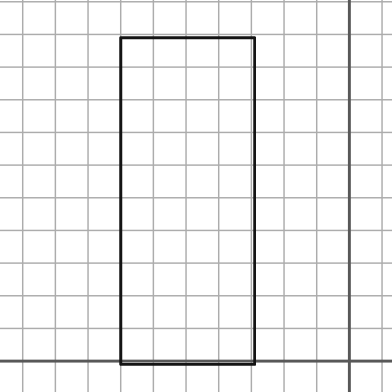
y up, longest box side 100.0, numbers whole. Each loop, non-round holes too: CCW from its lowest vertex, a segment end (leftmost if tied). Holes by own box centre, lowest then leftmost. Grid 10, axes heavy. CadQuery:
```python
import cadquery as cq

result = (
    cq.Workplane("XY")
    .moveTo(-70.0, -1.0)
    .lineTo(-29.0, -1.0)
    .lineTo(-29.0, 99.0)
    .lineTo(-70.0, 99.0)
    .close()
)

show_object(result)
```